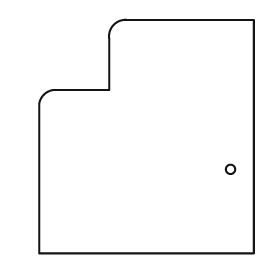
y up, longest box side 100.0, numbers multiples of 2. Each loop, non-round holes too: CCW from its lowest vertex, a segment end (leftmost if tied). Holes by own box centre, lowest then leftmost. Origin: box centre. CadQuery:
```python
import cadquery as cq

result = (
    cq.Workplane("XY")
    .moveTo(-46.0, -50.0)
    .lineTo(46.0, -50.0)
    .lineTo(46.0, 50.0)
    .lineTo(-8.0, 50.0)
    .threePointArc((-14.0, 48.0), (-16.0, 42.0))
    .lineTo(-16.0, 20.0)
    .lineTo(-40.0, 20.0)
    .threePointArc((-44.0, 18.0), (-46.0, 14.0))
    .close()
    .moveTo(36.0, -14.0)
    .circle(2.0)
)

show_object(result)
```